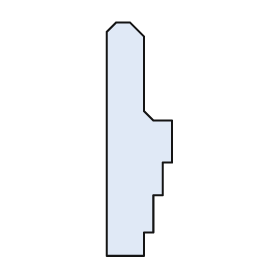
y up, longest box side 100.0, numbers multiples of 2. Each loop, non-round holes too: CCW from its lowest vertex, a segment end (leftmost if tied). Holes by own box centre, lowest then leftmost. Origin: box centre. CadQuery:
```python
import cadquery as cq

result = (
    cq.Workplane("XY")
    .moveTo(-14.0, -50.0)
    .lineTo(2.0, -50.0)
    .lineTo(2.0, -40.0)
    .lineTo(6.0, -40.0)
    .lineTo(6.0, -24.0)
    .lineTo(10.0, -24.0)
    .lineTo(10.0, -10.0)
    .lineTo(14.0, -10.0)
    .lineTo(14.0, 8.0)
    .lineTo(6.0, 8.0)
    .lineTo(2.0, 12.0)
    .lineTo(2.0, 44.0)
    .lineTo(-4.0, 50.0)
    .lineTo(-10.0, 50.0)
    .lineTo(-14.0, 46.0)
    .close()
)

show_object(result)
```